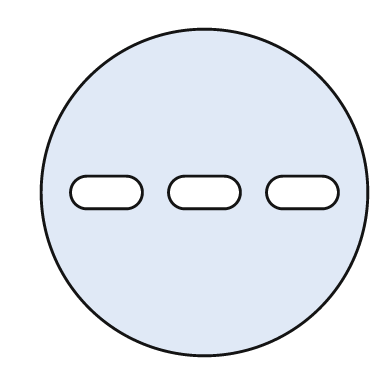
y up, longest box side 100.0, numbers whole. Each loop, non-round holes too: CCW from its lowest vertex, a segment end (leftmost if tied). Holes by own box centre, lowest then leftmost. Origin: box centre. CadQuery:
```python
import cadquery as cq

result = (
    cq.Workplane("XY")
    .moveTo(0.0, 0.0)
    .circle(50.0)
    .moveTo(-36.0, -5.0)
    .lineTo(-24.0, -5.0)
    .threePointArc((-19.0, 0.0), (-24.0, 5.0))
    .lineTo(-36.0, 5.0)
    .threePointArc((-41.0, 0.0), (-36.0, -5.0))
    .close()
    .moveTo(-6.0, -5.0)
    .lineTo(6.0, -5.0)
    .threePointArc((11.0, 0.0), (6.0, 5.0))
    .lineTo(-6.0, 5.0)
    .threePointArc((-11.0, 0.0), (-6.0, -5.0))
    .close()
    .moveTo(24.0, -5.0)
    .lineTo(36.0, -5.0)
    .threePointArc((41.0, 0.0), (36.0, 5.0))
    .lineTo(24.0, 5.0)
    .threePointArc((19.0, 0.0), (24.0, -5.0))
    .close()
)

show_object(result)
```